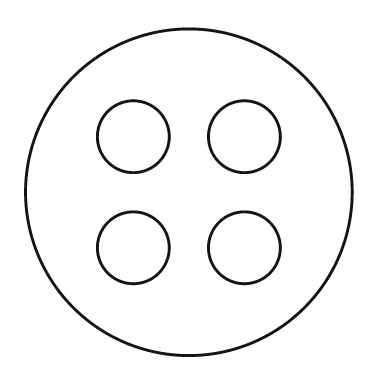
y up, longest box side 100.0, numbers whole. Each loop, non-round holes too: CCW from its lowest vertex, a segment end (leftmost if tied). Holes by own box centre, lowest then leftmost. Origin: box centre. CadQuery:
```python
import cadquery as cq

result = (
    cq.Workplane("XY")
    .moveTo(0.0, 0.0)
    .circle(50.0)
    .moveTo(-17.0, -17.0)
    .circle(11.0)
    .moveTo(17.0, -17.0)
    .circle(11.0)
    .moveTo(-17.0, 17.0)
    .circle(11.0)
    .moveTo(17.0, 17.0)
    .circle(11.0)
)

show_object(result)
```